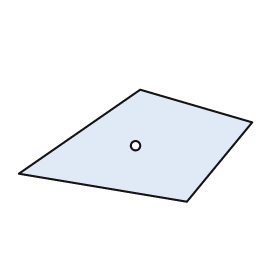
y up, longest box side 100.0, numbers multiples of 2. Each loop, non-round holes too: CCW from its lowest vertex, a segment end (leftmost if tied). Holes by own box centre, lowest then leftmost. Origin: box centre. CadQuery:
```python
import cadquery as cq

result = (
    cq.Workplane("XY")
    .moveTo(22.0, -24.0)
    .lineTo(50.0, 10.0)
    .lineTo(2.0, 24.0)
    .lineTo(-50.0, -12.0)
    .close()
    .moveTo(0.0, 0.0)
    .circle(2.0)
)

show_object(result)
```